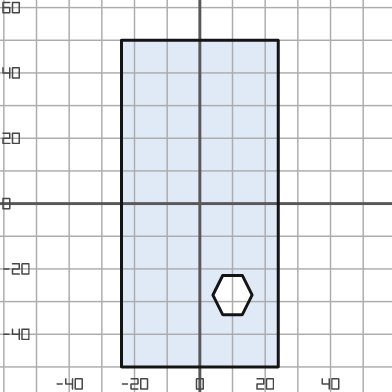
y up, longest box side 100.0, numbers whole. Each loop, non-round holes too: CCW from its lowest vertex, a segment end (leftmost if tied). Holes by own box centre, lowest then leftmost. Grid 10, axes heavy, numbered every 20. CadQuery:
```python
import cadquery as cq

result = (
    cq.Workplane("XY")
    .moveTo(-24.0, -50.0)
    .lineTo(24.0, -50.0)
    .lineTo(24.0, 50.0)
    .lineTo(-24.0, 50.0)
    .close()
    .moveTo(7.0, -34.0)
    .lineTo(13.0, -34.0)
    .lineTo(16.0, -28.0)
    .lineTo(13.0, -22.0)
    .lineTo(7.0, -22.0)
    .lineTo(4.0, -28.0)
    .close()
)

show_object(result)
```